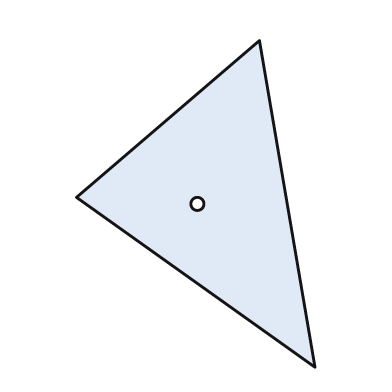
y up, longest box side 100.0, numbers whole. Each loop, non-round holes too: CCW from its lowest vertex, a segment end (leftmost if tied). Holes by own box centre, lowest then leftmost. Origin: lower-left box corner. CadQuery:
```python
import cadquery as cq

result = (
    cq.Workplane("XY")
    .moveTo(73.0, 0.0)
    .lineTo(56.0, 100.0)
    .lineTo(0.0, 52.0)
    .close()
    .moveTo(37.0, 50.0)
    .circle(2.0)
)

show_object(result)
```